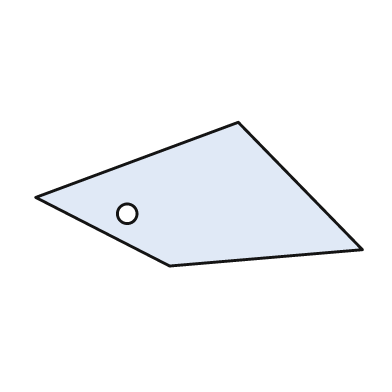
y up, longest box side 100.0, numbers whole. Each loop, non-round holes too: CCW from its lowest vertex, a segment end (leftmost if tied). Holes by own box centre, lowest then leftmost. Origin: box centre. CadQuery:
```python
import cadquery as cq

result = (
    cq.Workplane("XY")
    .moveTo(-9.0, -22.0)
    .lineTo(50.0, -17.0)
    .lineTo(12.0, 22.0)
    .lineTo(-50.0, -1.0)
    .close()
    .moveTo(-22.0, -6.0)
    .circle(3.0)
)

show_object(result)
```